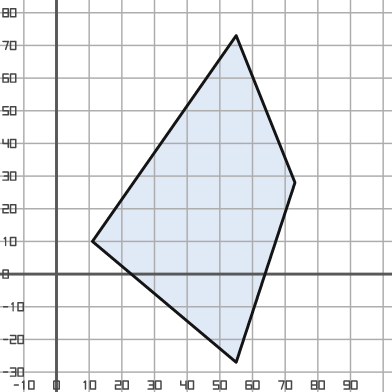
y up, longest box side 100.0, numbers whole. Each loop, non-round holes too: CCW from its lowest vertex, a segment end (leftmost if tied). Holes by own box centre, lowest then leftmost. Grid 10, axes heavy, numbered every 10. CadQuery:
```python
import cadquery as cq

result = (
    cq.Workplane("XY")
    .moveTo(55.0, -27.0)
    .lineTo(73.0, 28.0)
    .lineTo(55.0, 73.0)
    .lineTo(11.0, 10.0)
    .close()
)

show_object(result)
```